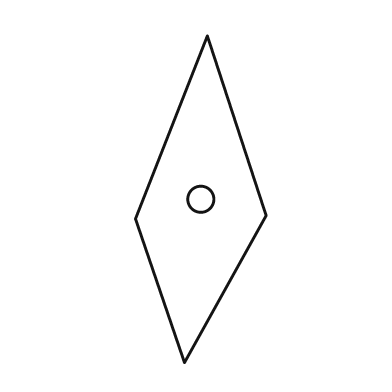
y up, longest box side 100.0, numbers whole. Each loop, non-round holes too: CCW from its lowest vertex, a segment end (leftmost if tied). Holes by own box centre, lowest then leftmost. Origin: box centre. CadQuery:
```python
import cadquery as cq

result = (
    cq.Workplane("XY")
    .moveTo(-5.0, -50.0)
    .lineTo(20.0, -5.0)
    .lineTo(2.0, 50.0)
    .lineTo(-20.0, -6.0)
    .close()
    .moveTo(0.0, 0.0)
    .circle(4.0)
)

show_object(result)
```